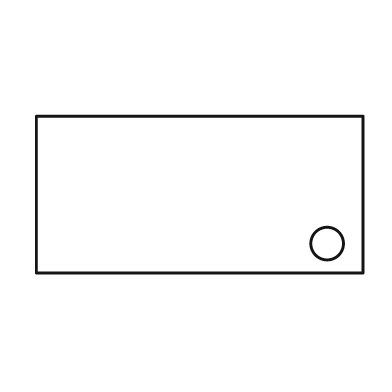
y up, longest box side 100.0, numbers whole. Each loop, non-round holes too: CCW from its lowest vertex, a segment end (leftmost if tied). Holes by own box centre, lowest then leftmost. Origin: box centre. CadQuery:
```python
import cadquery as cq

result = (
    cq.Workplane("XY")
    .moveTo(-50.0, -24.0)
    .lineTo(50.0, -24.0)
    .lineTo(50.0, 24.0)
    .lineTo(-50.0, 24.0)
    .close()
    .moveTo(39.0, -15.0)
    .circle(5.0)
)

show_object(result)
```